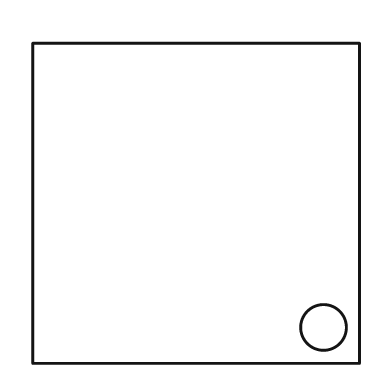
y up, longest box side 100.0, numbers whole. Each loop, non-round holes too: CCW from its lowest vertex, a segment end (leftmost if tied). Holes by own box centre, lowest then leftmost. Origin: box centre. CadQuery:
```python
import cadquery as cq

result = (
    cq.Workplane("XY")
    .moveTo(-50.0, -49.0)
    .lineTo(50.0, -49.0)
    .lineTo(50.0, 49.0)
    .lineTo(-50.0, 49.0)
    .close()
    .moveTo(39.0, -38.0)
    .circle(7.0)
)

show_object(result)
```